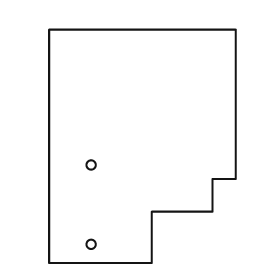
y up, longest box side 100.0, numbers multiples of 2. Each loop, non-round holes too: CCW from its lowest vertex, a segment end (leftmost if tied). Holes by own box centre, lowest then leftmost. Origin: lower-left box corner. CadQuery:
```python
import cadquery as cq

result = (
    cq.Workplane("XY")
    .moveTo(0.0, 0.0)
    .lineTo(44.0, 0.0)
    .lineTo(44.0, 22.0)
    .lineTo(70.0, 22.0)
    .lineTo(70.0, 36.0)
    .lineTo(80.0, 36.0)
    .lineTo(80.0, 100.0)
    .lineTo(0.0, 100.0)
    .close()
    .moveTo(18.0, 8.0)
    .circle(2.0)
    .moveTo(18.0, 42.0)
    .circle(2.0)
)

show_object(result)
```